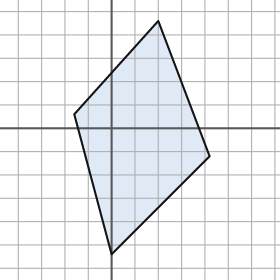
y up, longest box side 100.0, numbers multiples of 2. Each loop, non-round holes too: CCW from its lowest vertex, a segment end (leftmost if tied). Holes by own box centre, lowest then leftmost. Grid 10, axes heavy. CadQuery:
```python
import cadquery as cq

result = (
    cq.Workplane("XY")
    .moveTo(0.0, -54.0)
    .lineTo(42.0, -12.0)
    .lineTo(20.0, 46.0)
    .lineTo(-16.0, 6.0)
    .close()
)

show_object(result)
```